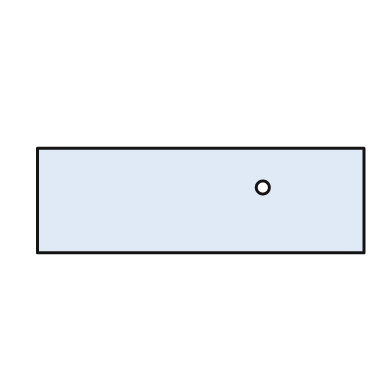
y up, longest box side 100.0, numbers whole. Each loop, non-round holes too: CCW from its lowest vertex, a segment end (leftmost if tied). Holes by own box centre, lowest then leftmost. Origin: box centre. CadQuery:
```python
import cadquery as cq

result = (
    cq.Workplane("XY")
    .moveTo(-50.0, -16.0)
    .lineTo(50.0, -16.0)
    .lineTo(50.0, 16.0)
    .lineTo(-50.0, 16.0)
    .close()
    .moveTo(19.0, 4.0)
    .circle(2.0)
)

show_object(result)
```